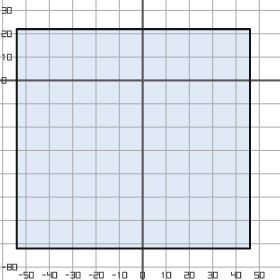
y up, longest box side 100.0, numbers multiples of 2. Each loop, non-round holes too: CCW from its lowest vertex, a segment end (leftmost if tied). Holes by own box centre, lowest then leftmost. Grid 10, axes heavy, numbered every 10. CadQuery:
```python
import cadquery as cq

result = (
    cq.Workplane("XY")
    .moveTo(-54.0, -72.0)
    .lineTo(46.0, -72.0)
    .lineTo(46.0, 22.0)
    .lineTo(-54.0, 22.0)
    .close()
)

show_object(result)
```